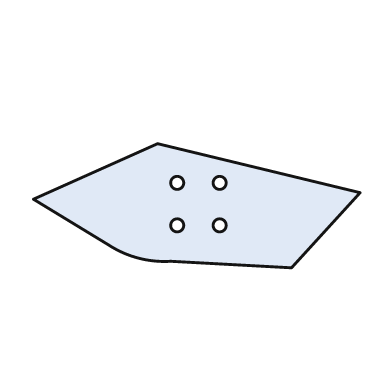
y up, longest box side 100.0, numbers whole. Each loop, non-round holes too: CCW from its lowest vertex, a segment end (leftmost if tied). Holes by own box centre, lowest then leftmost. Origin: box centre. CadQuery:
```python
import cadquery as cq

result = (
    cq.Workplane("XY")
    .moveTo(29.0, -19.0)
    .lineTo(50.0, 4.0)
    .lineTo(-12.0, 19.0)
    .lineTo(-50.0, 2.0)
    .lineTo(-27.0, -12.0)
    .threePointArc((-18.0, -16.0), (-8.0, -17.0))
    .close()
    .moveTo(-6.0, -6.0)
    .circle(2.0)
    .moveTo(7.0, -6.0)
    .circle(2.0)
    .moveTo(-6.0, 7.0)
    .circle(2.0)
    .moveTo(7.0, 7.0)
    .circle(2.0)
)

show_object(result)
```